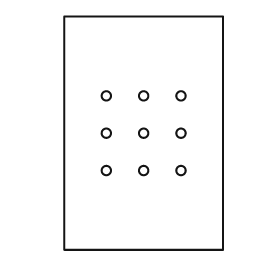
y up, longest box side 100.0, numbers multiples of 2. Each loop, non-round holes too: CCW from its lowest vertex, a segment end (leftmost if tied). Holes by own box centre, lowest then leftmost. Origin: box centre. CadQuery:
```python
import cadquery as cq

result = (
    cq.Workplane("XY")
    .moveTo(-34.0, -50.0)
    .lineTo(34.0, -50.0)
    .lineTo(34.0, 50.0)
    .lineTo(-34.0, 50.0)
    .close()
    .moveTo(-16.0, -16.0)
    .circle(2.0)
    .moveTo(0.0, -16.0)
    .circle(2.0)
    .moveTo(16.0, -16.0)
    .circle(2.0)
    .moveTo(-16.0, 0.0)
    .circle(2.0)
    .moveTo(0.0, 0.0)
    .circle(2.0)
    .moveTo(16.0, 0.0)
    .circle(2.0)
    .moveTo(-16.0, 16.0)
    .circle(2.0)
    .moveTo(0.0, 16.0)
    .circle(2.0)
    .moveTo(16.0, 16.0)
    .circle(2.0)
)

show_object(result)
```